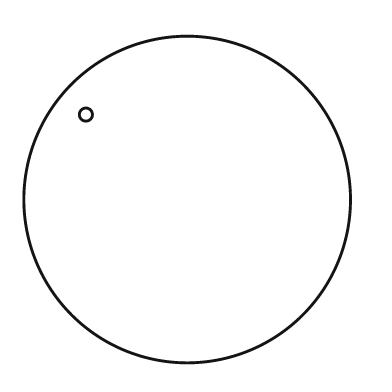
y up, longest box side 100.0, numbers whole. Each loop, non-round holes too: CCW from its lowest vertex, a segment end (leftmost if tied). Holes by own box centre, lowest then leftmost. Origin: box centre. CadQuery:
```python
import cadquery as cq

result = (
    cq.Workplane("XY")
    .moveTo(0.0, 0.0)
    .circle(50.0)
    .moveTo(-31.0, 26.0)
    .circle(2.0)
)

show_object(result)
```